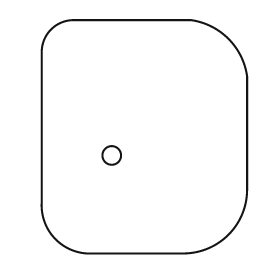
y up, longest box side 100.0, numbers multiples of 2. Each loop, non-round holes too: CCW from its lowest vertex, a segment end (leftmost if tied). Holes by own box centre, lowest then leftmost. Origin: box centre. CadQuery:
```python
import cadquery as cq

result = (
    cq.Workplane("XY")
    .moveTo(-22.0, -50.0)
    .lineTo(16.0, -50.0)
    .threePointArc((36.0, -42.0), (44.0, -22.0))
    .lineTo(44.0, 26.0)
    .threePointArc((36.0, 42.0), (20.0, 50.0))
    .lineTo(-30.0, 50.0)
    .threePointArc((-40.0, 46.0), (-44.0, 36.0))
    .lineTo(-44.0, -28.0)
    .threePointArc((-38.0, -44.0), (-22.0, -50.0))
    .close()
    .moveTo(-14.0, -8.0)
    .circle(4.0)
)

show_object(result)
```